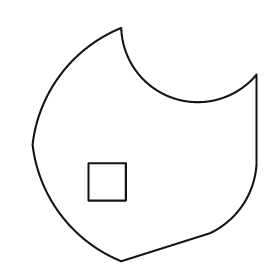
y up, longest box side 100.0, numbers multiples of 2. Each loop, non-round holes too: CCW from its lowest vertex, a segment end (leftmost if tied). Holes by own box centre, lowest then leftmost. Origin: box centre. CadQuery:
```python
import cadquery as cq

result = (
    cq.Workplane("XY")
    .moveTo(-10.0, -50.0)
    .lineTo(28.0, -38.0)
    .threePointArc((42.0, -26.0), (48.0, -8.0))
    .lineTo(48.0, 30.0)
    .threePointArc((12.0, 20.0), (-10.0, 50.0))
    .threePointArc((-36.0, 30.0), (-48.0, 0.0))
    .threePointArc((-36.0, -30.0), (-10.0, -50.0))
    .close()
    .moveTo(-24.0, -24.0)
    .lineTo(-8.0, -24.0)
    .lineTo(-8.0, -8.0)
    .lineTo(-24.0, -8.0)
    .close()
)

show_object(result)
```